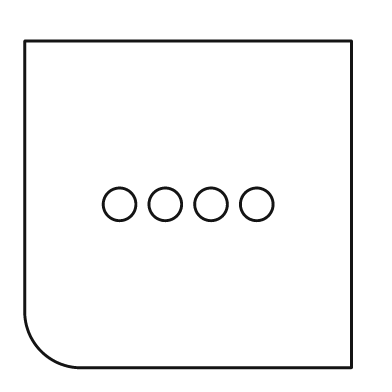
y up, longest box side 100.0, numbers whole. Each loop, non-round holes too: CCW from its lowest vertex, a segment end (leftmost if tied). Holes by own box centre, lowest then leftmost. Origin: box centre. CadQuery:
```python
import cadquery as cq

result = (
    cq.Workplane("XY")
    .moveTo(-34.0, -50.0)
    .lineTo(50.0, -50.0)
    .lineTo(50.0, 50.0)
    .lineTo(-50.0, 50.0)
    .lineTo(-50.0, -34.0)
    .threePointArc((-45.0, -45.0), (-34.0, -50.0))
    .close()
    .moveTo(-21.0, 0.0)
    .circle(5.0)
    .moveTo(-7.0, 0.0)
    .circle(5.0)
    .moveTo(7.0, 0.0)
    .circle(5.0)
    .moveTo(21.0, 0.0)
    .circle(5.0)
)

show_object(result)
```